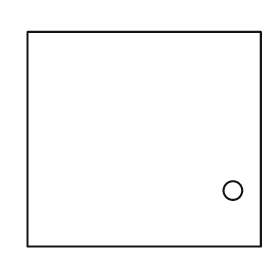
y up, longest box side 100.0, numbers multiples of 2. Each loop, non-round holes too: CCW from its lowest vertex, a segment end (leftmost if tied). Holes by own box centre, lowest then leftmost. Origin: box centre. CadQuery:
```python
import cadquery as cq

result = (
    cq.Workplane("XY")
    .moveTo(-50.0, -46.0)
    .lineTo(50.0, -46.0)
    .lineTo(50.0, 46.0)
    .lineTo(-50.0, 46.0)
    .close()
    .moveTo(38.0, -22.0)
    .circle(4.0)
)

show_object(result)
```